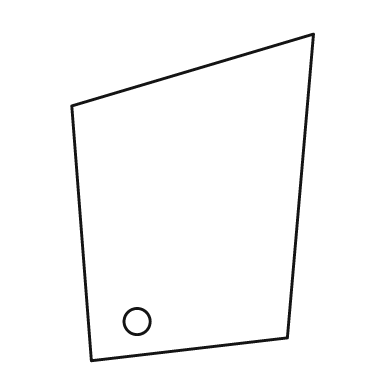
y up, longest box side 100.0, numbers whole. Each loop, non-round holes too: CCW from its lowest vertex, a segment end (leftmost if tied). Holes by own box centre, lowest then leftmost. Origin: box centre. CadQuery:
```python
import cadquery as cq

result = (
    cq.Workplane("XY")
    .moveTo(-31.0, -50.0)
    .lineTo(29.0, -43.0)
    .lineTo(37.0, 50.0)
    .lineTo(-37.0, 28.0)
    .close()
    .moveTo(-17.0, -38.0)
    .circle(4.0)
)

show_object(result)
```